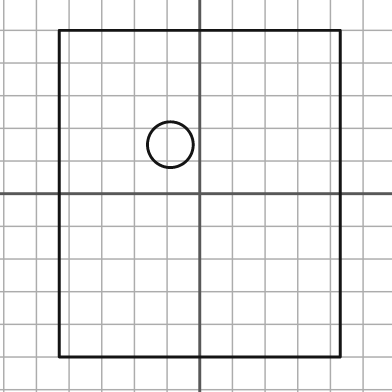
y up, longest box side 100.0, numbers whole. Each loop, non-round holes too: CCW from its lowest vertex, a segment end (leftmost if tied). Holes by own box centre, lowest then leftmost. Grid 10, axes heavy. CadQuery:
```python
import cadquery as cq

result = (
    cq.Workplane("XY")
    .moveTo(-43.0, -50.0)
    .lineTo(43.0, -50.0)
    .lineTo(43.0, 50.0)
    .lineTo(-43.0, 50.0)
    .close()
    .moveTo(-9.0, 15.0)
    .circle(7.0)
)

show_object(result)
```